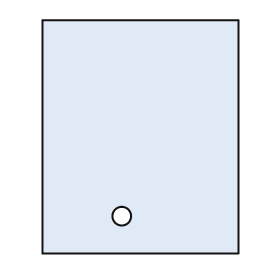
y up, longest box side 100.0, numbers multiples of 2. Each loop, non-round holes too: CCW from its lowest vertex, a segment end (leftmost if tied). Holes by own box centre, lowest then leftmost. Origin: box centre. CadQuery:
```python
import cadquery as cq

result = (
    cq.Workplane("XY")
    .moveTo(-42.0, -50.0)
    .lineTo(42.0, -50.0)
    .lineTo(42.0, 50.0)
    .lineTo(-42.0, 50.0)
    .close()
    .moveTo(-8.0, -34.0)
    .circle(4.0)
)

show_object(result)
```